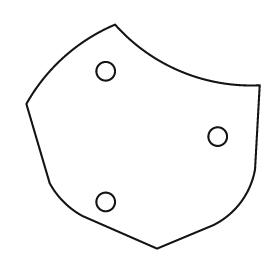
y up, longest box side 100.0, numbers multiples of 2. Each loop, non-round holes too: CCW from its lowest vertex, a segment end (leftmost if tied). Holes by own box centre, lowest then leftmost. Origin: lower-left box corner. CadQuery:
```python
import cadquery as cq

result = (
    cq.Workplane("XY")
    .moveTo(56.0, 0.0)
    .lineTo(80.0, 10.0)
    .threePointArc((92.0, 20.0), (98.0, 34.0))
    .lineTo(100.0, 70.0)
    .threePointArc((66.0, 76.0), (38.0, 96.0))
    .threePointArc((16.0, 82.0), (0.0, 62.0))
    .lineTo(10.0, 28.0)
    .threePointArc((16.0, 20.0), (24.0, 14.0))
    .close()
    .moveTo(34.0, 20.0)
    .circle(4.0)
    .moveTo(82.0, 48.0)
    .circle(4.0)
    .moveTo(34.0, 76.0)
    .circle(4.0)
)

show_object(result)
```